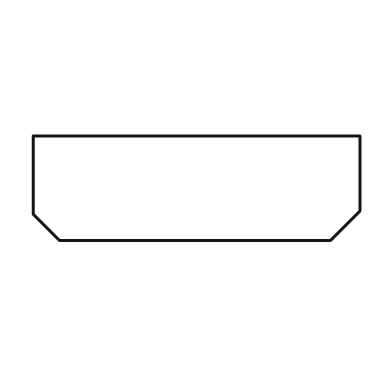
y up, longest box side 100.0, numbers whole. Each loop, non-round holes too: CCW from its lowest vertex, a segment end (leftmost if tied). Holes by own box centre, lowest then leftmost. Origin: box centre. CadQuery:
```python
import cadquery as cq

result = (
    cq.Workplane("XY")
    .moveTo(-42.0, -16.0)
    .lineTo(41.0, -16.0)
    .lineTo(50.0, -7.0)
    .lineTo(50.0, 16.0)
    .lineTo(-50.0, 16.0)
    .lineTo(-50.0, -8.0)
    .close()
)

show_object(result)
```